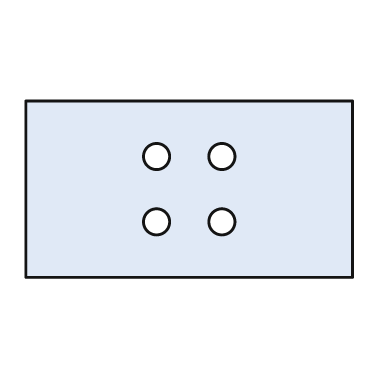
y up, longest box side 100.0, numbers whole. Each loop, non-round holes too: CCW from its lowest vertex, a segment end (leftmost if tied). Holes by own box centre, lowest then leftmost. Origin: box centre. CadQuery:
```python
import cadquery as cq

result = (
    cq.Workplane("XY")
    .moveTo(-50.0, -27.0)
    .lineTo(50.0, -27.0)
    .lineTo(50.0, 27.0)
    .lineTo(-50.0, 27.0)
    .close()
    .moveTo(-10.0, -10.0)
    .circle(4.0)
    .moveTo(10.0, -10.0)
    .circle(4.0)
    .moveTo(-10.0, 10.0)
    .circle(4.0)
    .moveTo(10.0, 10.0)
    .circle(4.0)
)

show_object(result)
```